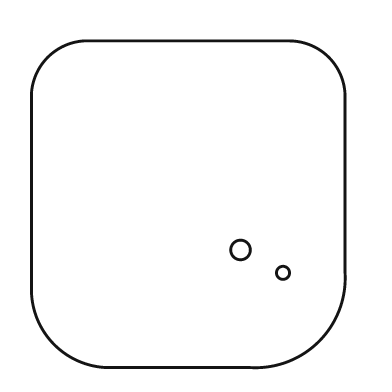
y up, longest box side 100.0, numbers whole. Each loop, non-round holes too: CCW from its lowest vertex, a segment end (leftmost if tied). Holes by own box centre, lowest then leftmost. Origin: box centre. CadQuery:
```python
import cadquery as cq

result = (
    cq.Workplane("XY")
    .moveTo(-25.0, -50.0)
    .lineTo(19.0, -50.0)
    .threePointArc((40.0, -42.0), (48.0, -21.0))
    .lineTo(48.0, 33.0)
    .threePointArc((43.0, 45.0), (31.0, 50.0))
    .lineTo(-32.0, 50.0)
    .threePointArc((-43.0, 45.0), (-48.0, 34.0))
    .lineTo(-48.0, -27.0)
    .threePointArc((-41.0, -43.0), (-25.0, -50.0))
    .close()
    .moveTo(29.0, -21.0)
    .circle(2.0)
    .moveTo(16.0, -14.0)
    .circle(3.0)
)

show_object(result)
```